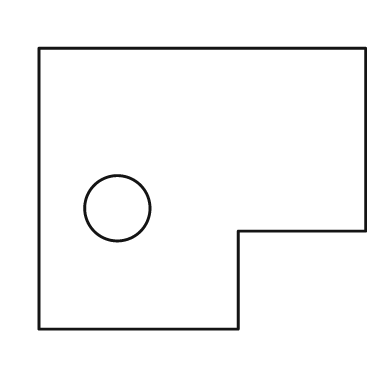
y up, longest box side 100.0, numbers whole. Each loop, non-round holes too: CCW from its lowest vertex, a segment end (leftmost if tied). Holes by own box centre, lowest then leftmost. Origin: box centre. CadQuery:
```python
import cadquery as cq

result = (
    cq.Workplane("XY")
    .moveTo(-50.0, -43.0)
    .lineTo(11.0, -43.0)
    .lineTo(11.0, -13.0)
    .lineTo(50.0, -13.0)
    .lineTo(50.0, 43.0)
    .lineTo(-50.0, 43.0)
    .close()
    .moveTo(-26.0, -6.0)
    .circle(10.0)
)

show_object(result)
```